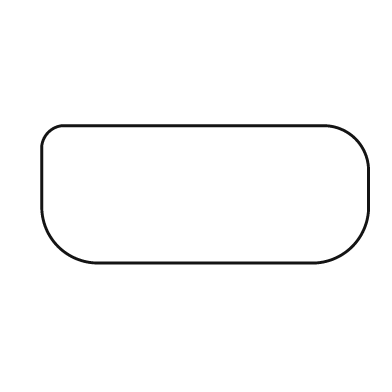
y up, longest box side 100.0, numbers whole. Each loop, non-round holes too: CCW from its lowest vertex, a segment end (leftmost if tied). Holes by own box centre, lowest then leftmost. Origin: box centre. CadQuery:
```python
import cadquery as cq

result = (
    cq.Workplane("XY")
    .moveTo(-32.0, -21.0)
    .lineTo(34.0, -21.0)
    .threePointArc((45.0, -16.0), (50.0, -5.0))
    .lineTo(50.0, 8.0)
    .threePointArc((46.0, 17.0), (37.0, 21.0))
    .lineTo(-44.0, 21.0)
    .threePointArc((-48.0, 19.0), (-50.0, 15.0))
    .lineTo(-50.0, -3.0)
    .threePointArc((-45.0, -16.0), (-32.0, -21.0))
    .close()
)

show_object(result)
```